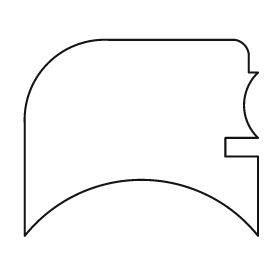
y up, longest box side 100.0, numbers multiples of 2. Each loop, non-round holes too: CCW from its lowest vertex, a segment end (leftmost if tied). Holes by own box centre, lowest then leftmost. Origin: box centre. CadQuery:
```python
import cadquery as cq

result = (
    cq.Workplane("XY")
    .moveTo(-50.0, -42.0)
    .threePointArc((0.0, -18.0), (50.0, -42.0))
    .lineTo(50.0, -8.0)
    .lineTo(36.0, -8.0)
    .lineTo(36.0, 0.0)
    .lineTo(50.0, 0.0)
    .threePointArc((44.0, 14.0), (50.0, 28.0))
    .lineTo(46.0, 28.0)
    .lineTo(46.0, 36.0)
    .threePointArc((44.0, 40.0), (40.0, 42.0))
    .lineTo(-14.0, 42.0)
    .threePointArc((-40.0, 32.0), (-50.0, 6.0))
    .close()
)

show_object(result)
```